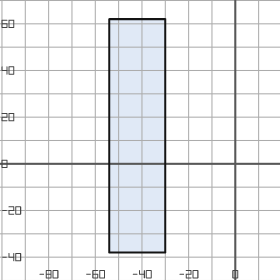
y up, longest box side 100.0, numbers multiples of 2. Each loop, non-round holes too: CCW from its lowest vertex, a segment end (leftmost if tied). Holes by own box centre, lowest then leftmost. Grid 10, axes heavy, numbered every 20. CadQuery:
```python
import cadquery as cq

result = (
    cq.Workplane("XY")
    .moveTo(-54.0, -38.0)
    .lineTo(-30.0, -38.0)
    .lineTo(-30.0, 62.0)
    .lineTo(-54.0, 62.0)
    .close()
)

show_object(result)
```